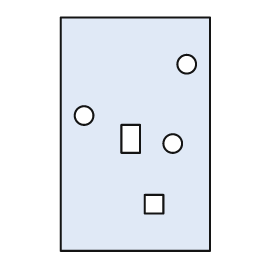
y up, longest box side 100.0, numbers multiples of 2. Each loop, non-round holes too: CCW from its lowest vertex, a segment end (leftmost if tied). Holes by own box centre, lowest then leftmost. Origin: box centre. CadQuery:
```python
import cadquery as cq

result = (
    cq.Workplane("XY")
    .moveTo(-32.0, -50.0)
    .lineTo(32.0, -50.0)
    .lineTo(32.0, 50.0)
    .lineTo(-32.0, 50.0)
    .close()
    .moveTo(4.0, -34.0)
    .lineTo(12.0, -34.0)
    .lineTo(12.0, -26.0)
    .lineTo(4.0, -26.0)
    .close()
    .moveTo(16.0, -4.0)
    .circle(4.0)
    .moveTo(-6.0, -8.0)
    .lineTo(2.0, -8.0)
    .lineTo(2.0, 4.0)
    .lineTo(-6.0, 4.0)
    .close()
    .moveTo(-22.0, 8.0)
    .circle(4.0)
    .moveTo(22.0, 30.0)
    .circle(4.0)
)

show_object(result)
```